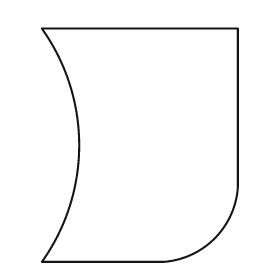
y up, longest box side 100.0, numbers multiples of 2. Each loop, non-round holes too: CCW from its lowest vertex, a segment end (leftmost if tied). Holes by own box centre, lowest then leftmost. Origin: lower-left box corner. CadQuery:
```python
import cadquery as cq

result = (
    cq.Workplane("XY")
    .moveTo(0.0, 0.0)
    .lineTo(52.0, 0.0)
    .threePointArc((74.0, 10.0), (84.0, 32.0))
    .lineTo(84.0, 100.0)
    .lineTo(0.0, 100.0)
    .threePointArc((16.0, 50.0), (0.0, 0.0))
    .close()
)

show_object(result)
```